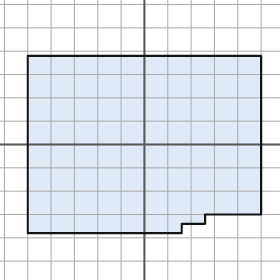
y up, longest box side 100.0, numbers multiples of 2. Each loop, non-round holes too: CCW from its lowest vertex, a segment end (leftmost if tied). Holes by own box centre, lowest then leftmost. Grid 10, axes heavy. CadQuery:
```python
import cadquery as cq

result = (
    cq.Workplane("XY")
    .moveTo(-50.0, -38.0)
    .lineTo(16.0, -38.0)
    .lineTo(16.0, -34.0)
    .lineTo(26.0, -34.0)
    .lineTo(26.0, -30.0)
    .lineTo(50.0, -30.0)
    .lineTo(50.0, 38.0)
    .lineTo(-50.0, 38.0)
    .close()
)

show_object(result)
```